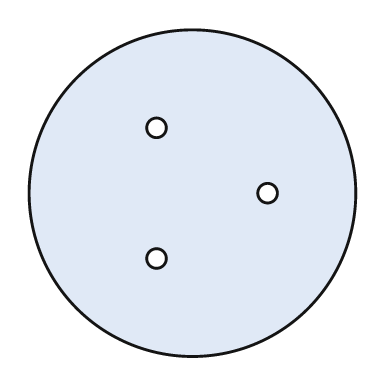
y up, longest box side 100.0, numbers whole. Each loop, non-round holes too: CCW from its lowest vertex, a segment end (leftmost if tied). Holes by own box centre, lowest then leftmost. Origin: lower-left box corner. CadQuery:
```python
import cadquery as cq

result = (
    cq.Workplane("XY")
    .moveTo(50.0, 50.0)
    .circle(50.0)
    .moveTo(39.0, 30.0)
    .circle(3.0)
    .moveTo(73.0, 50.0)
    .circle(3.0)
    .moveTo(39.0, 70.0)
    .circle(3.0)
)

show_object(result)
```